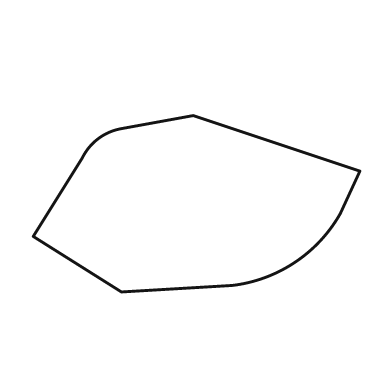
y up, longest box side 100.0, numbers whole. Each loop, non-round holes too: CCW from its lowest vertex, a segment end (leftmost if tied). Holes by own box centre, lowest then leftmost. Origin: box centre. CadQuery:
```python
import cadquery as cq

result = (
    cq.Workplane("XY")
    .moveTo(-23.0, -27.0)
    .lineTo(11.0, -25.0)
    .threePointArc((30.0, -18.0), (44.0, -3.0))
    .lineTo(50.0, 10.0)
    .lineTo(-1.0, 27.0)
    .lineTo(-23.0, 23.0)
    .threePointArc((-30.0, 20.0), (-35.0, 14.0))
    .lineTo(-50.0, -10.0)
    .close()
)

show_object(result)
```